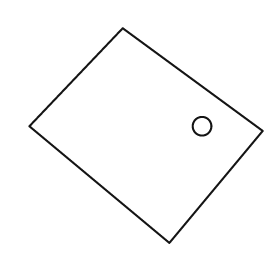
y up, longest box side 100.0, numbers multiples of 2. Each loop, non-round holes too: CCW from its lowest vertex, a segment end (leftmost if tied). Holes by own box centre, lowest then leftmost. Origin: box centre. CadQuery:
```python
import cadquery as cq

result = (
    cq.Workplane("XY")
    .moveTo(10.0, -46.0)
    .lineTo(50.0, 2.0)
    .lineTo(-10.0, 46.0)
    .lineTo(-50.0, 4.0)
    .close()
    .moveTo(24.0, 4.0)
    .circle(4.0)
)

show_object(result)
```